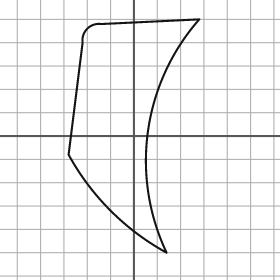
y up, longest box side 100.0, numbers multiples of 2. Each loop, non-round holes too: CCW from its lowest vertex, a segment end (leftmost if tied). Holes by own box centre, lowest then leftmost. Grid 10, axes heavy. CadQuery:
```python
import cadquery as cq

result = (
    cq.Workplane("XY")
    .moveTo(14.0, -50.0)
    .threePointArc((6.0, 2.0), (28.0, 50.0))
    .lineTo(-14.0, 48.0)
    .threePointArc((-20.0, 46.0), (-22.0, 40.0))
    .lineTo(-28.0, -8.0)
    .threePointArc((-10.0, -32.0), (14.0, -50.0))
    .close()
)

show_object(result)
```